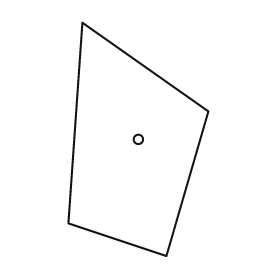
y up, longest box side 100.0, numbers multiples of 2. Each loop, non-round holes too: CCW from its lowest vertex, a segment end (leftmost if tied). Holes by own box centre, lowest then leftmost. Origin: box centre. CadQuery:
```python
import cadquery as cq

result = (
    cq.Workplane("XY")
    .moveTo(12.0, -50.0)
    .lineTo(30.0, 12.0)
    .lineTo(-24.0, 50.0)
    .lineTo(-30.0, -36.0)
    .close()
    .moveTo(0.0, 0.0)
    .circle(2.0)
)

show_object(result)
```